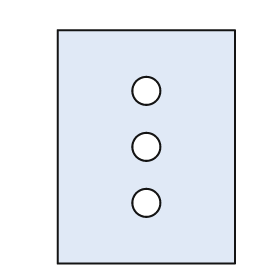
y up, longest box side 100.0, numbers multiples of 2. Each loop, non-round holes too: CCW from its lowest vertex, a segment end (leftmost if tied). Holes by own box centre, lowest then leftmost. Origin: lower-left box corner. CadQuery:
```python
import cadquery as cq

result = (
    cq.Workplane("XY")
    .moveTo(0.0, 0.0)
    .lineTo(76.0, 0.0)
    .lineTo(76.0, 100.0)
    .lineTo(0.0, 100.0)
    .close()
    .moveTo(38.0, 26.0)
    .circle(6.0)
    .moveTo(38.0, 50.0)
    .circle(6.0)
    .moveTo(38.0, 74.0)
    .circle(6.0)
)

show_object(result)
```